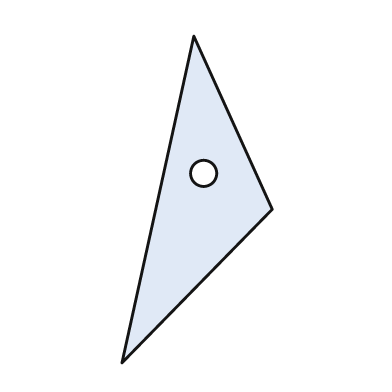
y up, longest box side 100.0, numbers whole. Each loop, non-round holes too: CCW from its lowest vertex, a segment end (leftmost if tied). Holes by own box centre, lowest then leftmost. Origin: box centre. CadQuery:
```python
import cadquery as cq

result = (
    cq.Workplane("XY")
    .moveTo(-23.0, -50.0)
    .lineTo(23.0, -3.0)
    .lineTo(-1.0, 50.0)
    .close()
    .moveTo(2.0, 8.0)
    .circle(4.0)
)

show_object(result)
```